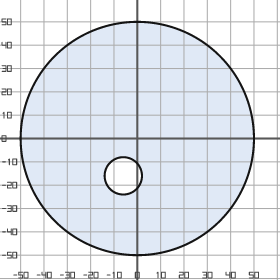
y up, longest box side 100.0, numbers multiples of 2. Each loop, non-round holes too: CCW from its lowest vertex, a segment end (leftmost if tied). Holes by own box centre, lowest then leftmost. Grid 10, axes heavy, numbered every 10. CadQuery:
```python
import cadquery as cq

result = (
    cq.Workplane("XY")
    .moveTo(0.0, 0.0)
    .circle(50.0)
    .moveTo(-6.0, -16.0)
    .circle(8.0)
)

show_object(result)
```